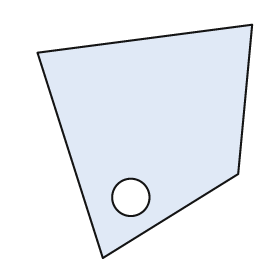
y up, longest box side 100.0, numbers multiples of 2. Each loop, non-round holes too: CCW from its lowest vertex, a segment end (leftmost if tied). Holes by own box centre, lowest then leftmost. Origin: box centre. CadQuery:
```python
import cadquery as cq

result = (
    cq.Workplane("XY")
    .moveTo(-18.0, -50.0)
    .lineTo(40.0, -14.0)
    .lineTo(46.0, 50.0)
    .lineTo(-46.0, 38.0)
    .close()
    .moveTo(-6.0, -24.0)
    .circle(8.0)
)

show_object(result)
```